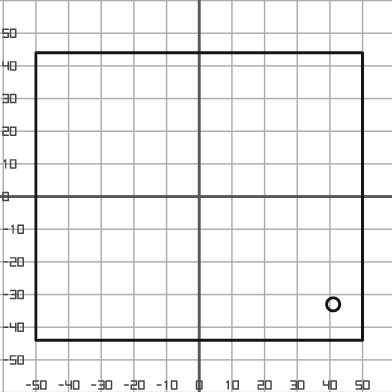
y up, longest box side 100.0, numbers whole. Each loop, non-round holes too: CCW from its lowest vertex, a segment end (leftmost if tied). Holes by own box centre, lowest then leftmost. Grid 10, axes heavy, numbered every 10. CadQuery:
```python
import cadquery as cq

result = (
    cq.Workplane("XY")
    .moveTo(-50.0, -44.0)
    .lineTo(50.0, -44.0)
    .lineTo(50.0, 44.0)
    .lineTo(-50.0, 44.0)
    .close()
    .moveTo(41.0, -33.0)
    .circle(2.0)
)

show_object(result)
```